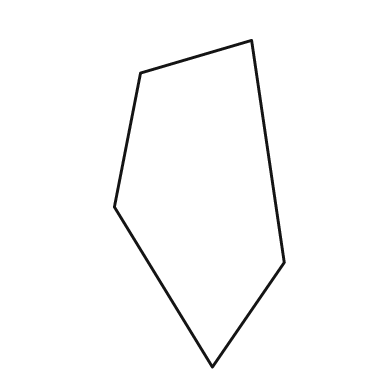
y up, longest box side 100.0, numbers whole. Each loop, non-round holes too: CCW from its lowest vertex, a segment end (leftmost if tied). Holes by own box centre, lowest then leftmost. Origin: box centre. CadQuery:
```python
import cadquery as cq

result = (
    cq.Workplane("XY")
    .moveTo(4.0, -50.0)
    .lineTo(26.0, -18.0)
    .lineTo(16.0, 50.0)
    .lineTo(-18.0, 40.0)
    .lineTo(-26.0, -1.0)
    .close()
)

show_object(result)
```